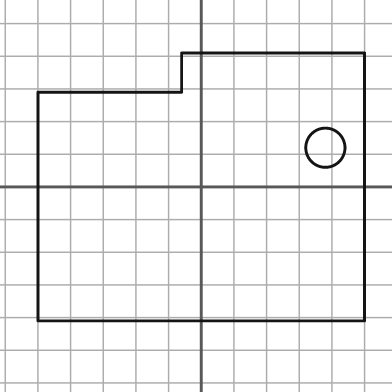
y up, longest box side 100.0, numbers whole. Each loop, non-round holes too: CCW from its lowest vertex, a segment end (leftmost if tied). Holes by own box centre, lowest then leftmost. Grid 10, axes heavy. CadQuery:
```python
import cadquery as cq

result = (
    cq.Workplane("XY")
    .moveTo(-50.0, -41.0)
    .lineTo(50.0, -41.0)
    .lineTo(50.0, 41.0)
    .lineTo(-6.0, 41.0)
    .lineTo(-6.0, 29.0)
    .lineTo(-50.0, 29.0)
    .close()
    .moveTo(38.0, 12.0)
    .circle(6.0)
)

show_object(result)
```